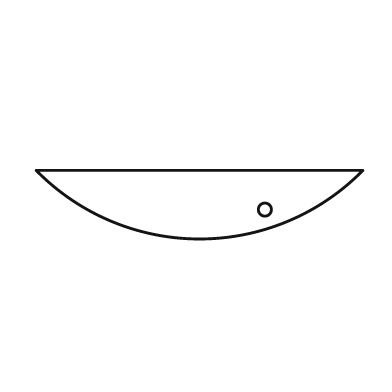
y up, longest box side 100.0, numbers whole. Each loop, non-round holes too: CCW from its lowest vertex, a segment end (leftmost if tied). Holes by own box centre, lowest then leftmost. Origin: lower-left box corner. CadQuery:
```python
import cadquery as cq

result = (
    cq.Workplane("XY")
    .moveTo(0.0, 21.0)
    .threePointArc((50.0, 0.0), (100.0, 21.0))
    .close()
    .moveTo(70.0, 9.0)
    .circle(2.0)
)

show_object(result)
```